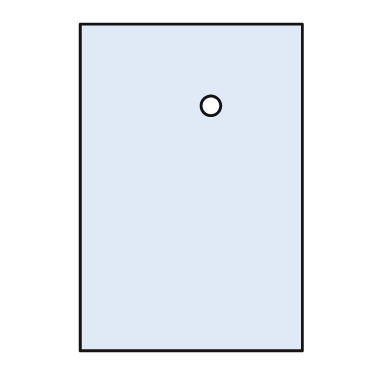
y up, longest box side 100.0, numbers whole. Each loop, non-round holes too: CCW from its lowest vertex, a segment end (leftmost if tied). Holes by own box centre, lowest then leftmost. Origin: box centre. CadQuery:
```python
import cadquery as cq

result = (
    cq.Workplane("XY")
    .moveTo(-34.0, -50.0)
    .lineTo(34.0, -50.0)
    .lineTo(34.0, 50.0)
    .lineTo(-34.0, 50.0)
    .close()
    .moveTo(6.0, 25.0)
    .circle(3.0)
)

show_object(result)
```